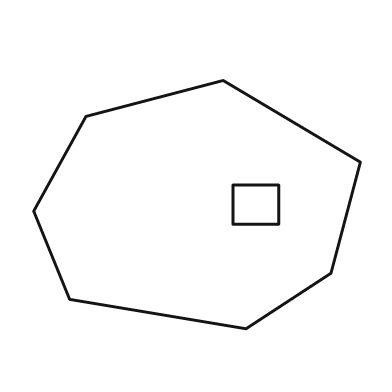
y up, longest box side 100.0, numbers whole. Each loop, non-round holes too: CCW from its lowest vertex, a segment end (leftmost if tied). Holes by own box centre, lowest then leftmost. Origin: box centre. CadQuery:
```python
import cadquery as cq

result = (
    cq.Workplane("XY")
    .moveTo(15.0, -38.0)
    .lineTo(41.0, -21.0)
    .lineTo(50.0, 13.0)
    .lineTo(8.0, 38.0)
    .lineTo(-34.0, 27.0)
    .lineTo(-50.0, -2.0)
    .lineTo(-39.0, -29.0)
    .close()
    .moveTo(11.0, -6.0)
    .lineTo(25.0, -6.0)
    .lineTo(25.0, 6.0)
    .lineTo(11.0, 6.0)
    .close()
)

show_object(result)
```